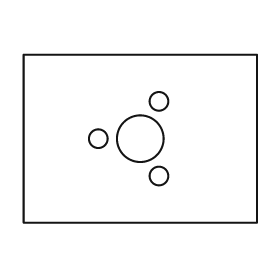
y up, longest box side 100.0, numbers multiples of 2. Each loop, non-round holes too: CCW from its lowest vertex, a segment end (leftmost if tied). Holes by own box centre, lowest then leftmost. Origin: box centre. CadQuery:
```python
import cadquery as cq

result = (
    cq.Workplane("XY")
    .moveTo(-50.0, -36.0)
    .lineTo(50.0, -36.0)
    .lineTo(50.0, 36.0)
    .lineTo(-50.0, 36.0)
    .close()
    .moveTo(8.0, -16.0)
    .circle(4.0)
    .moveTo(-18.0, 0.0)
    .circle(4.0)
    .moveTo(0.0, 0.0)
    .circle(10.0)
    .moveTo(8.0, 16.0)
    .circle(4.0)
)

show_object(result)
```